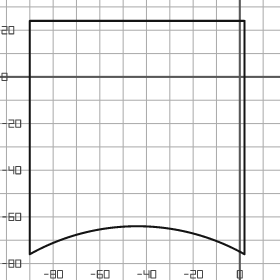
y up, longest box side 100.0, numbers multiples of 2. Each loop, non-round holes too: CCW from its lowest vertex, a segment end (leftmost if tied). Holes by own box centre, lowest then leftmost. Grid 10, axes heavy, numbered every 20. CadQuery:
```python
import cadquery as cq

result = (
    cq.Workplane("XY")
    .moveTo(-90.0, -76.0)
    .threePointArc((-44.0, -64.0), (2.0, -76.0))
    .lineTo(2.0, 24.0)
    .lineTo(-90.0, 24.0)
    .close()
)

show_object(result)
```